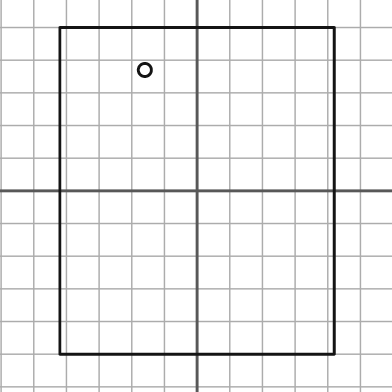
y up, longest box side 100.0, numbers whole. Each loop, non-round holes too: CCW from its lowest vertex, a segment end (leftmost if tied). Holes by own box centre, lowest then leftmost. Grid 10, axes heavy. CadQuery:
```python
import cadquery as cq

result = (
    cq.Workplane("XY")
    .moveTo(-42.0, -50.0)
    .lineTo(42.0, -50.0)
    .lineTo(42.0, 50.0)
    .lineTo(-42.0, 50.0)
    .close()
    .moveTo(-16.0, 37.0)
    .circle(2.0)
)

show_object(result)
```